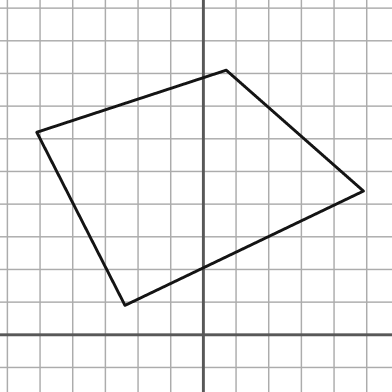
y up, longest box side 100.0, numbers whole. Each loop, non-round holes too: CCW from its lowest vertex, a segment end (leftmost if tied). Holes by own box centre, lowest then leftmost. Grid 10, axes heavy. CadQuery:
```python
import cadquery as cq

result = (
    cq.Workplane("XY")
    .moveTo(-24.0, 9.0)
    .lineTo(49.0, 44.0)
    .lineTo(7.0, 81.0)
    .lineTo(-51.0, 62.0)
    .close()
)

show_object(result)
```